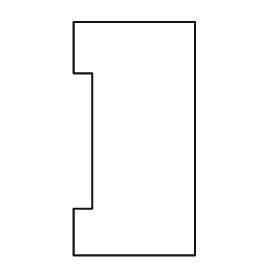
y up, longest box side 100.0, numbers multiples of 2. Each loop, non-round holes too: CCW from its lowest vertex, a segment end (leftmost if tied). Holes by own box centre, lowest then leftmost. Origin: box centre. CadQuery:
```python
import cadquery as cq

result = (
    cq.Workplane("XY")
    .moveTo(-26.0, -50.0)
    .lineTo(26.0, -50.0)
    .lineTo(26.0, 50.0)
    .lineTo(-26.0, 50.0)
    .lineTo(-26.0, 28.0)
    .lineTo(-18.0, 28.0)
    .lineTo(-18.0, -30.0)
    .lineTo(-26.0, -30.0)
    .close()
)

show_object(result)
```